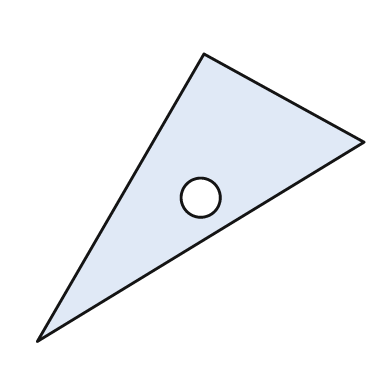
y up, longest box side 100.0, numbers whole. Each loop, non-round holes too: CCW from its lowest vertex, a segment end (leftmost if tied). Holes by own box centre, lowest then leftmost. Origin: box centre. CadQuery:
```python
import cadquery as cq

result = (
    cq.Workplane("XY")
    .moveTo(-50.0, -44.0)
    .lineTo(50.0, 17.0)
    .lineTo(1.0, 44.0)
    .close()
    .moveTo(0.0, 0.0)
    .circle(6.0)
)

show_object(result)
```